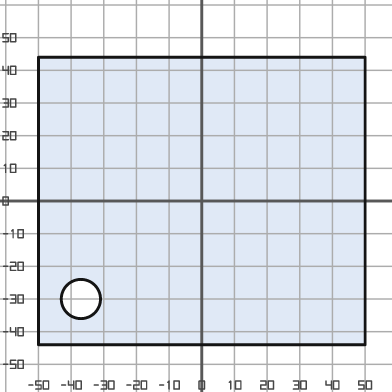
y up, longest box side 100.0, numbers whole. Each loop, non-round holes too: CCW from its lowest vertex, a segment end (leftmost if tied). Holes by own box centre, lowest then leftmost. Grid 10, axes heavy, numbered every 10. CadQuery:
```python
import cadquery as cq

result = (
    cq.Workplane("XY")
    .moveTo(-50.0, -44.0)
    .lineTo(50.0, -44.0)
    .lineTo(50.0, 44.0)
    .lineTo(-50.0, 44.0)
    .close()
    .moveTo(-37.0, -30.0)
    .circle(6.0)
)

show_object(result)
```